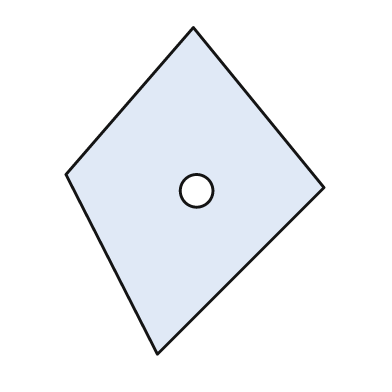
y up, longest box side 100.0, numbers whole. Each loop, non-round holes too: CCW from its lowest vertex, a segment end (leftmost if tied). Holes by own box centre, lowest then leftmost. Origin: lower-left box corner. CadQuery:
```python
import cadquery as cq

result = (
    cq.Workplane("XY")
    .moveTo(28.0, 0.0)
    .lineTo(79.0, 51.0)
    .lineTo(39.0, 100.0)
    .lineTo(0.0, 55.0)
    .close()
    .moveTo(40.0, 50.0)
    .circle(5.0)
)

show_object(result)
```